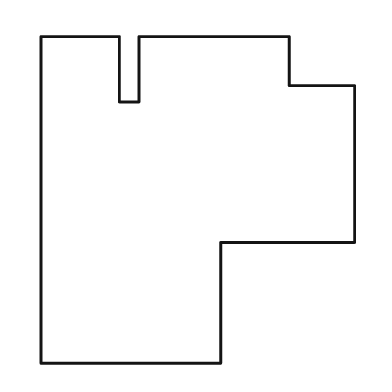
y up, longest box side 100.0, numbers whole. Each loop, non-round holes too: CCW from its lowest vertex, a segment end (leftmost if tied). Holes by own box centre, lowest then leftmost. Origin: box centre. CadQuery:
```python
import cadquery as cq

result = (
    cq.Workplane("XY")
    .moveTo(-48.0, -50.0)
    .lineTo(7.0, -50.0)
    .lineTo(7.0, -13.0)
    .lineTo(48.0, -13.0)
    .lineTo(48.0, 35.0)
    .lineTo(28.0, 35.0)
    .lineTo(28.0, 50.0)
    .lineTo(-18.0, 50.0)
    .lineTo(-18.0, 30.0)
    .lineTo(-24.0, 30.0)
    .lineTo(-24.0, 50.0)
    .lineTo(-48.0, 50.0)
    .close()
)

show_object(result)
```